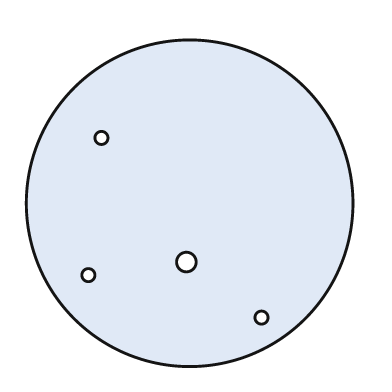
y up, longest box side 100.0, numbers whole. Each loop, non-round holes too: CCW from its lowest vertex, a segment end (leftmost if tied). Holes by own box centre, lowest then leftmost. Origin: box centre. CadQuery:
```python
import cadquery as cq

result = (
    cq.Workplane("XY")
    .moveTo(0.0, 0.0)
    .circle(50.0)
    .moveTo(22.0, -35.0)
    .circle(2.0)
    .moveTo(-31.0, -22.0)
    .circle(2.0)
    .moveTo(-1.0, -18.0)
    .circle(3.0)
    .moveTo(-27.0, 20.0)
    .circle(2.0)
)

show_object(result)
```